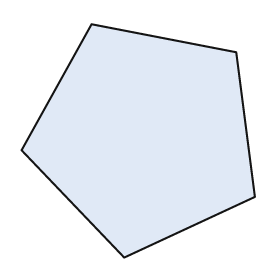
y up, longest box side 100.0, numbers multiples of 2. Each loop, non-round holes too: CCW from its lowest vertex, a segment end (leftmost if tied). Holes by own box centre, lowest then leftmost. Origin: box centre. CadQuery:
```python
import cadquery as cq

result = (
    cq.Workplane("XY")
    .moveTo(-6.0, -50.0)
    .lineTo(50.0, -24.0)
    .lineTo(42.0, 38.0)
    .lineTo(-20.0, 50.0)
    .lineTo(-50.0, -4.0)
    .close()
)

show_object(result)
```